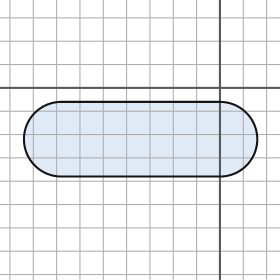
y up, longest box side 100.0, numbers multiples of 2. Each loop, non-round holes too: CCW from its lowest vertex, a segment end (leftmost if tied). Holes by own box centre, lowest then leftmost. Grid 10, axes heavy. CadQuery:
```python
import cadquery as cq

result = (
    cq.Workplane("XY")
    .moveTo(-68.0, -38.0)
    .lineTo(0.0, -38.0)
    .threePointArc((16.0, -22.0), (0.0, -6.0))
    .lineTo(-68.0, -6.0)
    .threePointArc((-84.0, -22.0), (-68.0, -38.0))
    .close()
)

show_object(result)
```